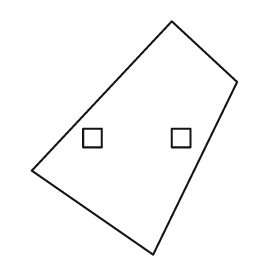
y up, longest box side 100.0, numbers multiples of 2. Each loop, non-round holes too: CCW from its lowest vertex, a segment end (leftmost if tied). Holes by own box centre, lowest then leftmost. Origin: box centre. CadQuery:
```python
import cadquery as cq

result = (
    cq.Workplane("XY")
    .moveTo(8.0, -50.0)
    .lineTo(44.0, 24.0)
    .lineTo(16.0, 50.0)
    .lineTo(-44.0, -14.0)
    .close()
    .moveTo(-22.0, -4.0)
    .lineTo(-14.0, -4.0)
    .lineTo(-14.0, 4.0)
    .lineTo(-22.0, 4.0)
    .close()
    .moveTo(16.0, -4.0)
    .lineTo(24.0, -4.0)
    .lineTo(24.0, 4.0)
    .lineTo(16.0, 4.0)
    .close()
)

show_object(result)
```